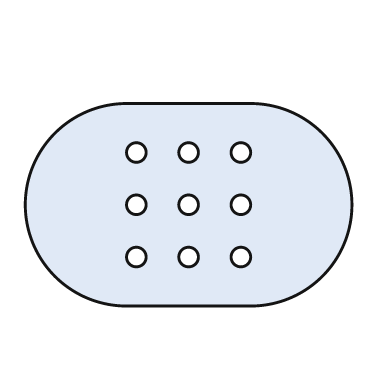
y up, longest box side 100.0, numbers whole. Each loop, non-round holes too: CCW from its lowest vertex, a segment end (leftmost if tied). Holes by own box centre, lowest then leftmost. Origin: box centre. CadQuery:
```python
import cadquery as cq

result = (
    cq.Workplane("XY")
    .moveTo(-19.0, -31.0)
    .lineTo(19.0, -31.0)
    .threePointArc((50.0, 0.0), (19.0, 31.0))
    .lineTo(-19.0, 31.0)
    .threePointArc((-50.0, 0.0), (-19.0, -31.0))
    .close()
    .moveTo(-16.0, -16.0)
    .circle(3.0)
    .moveTo(0.0, -16.0)
    .circle(3.0)
    .moveTo(16.0, -16.0)
    .circle(3.0)
    .moveTo(-16.0, 0.0)
    .circle(3.0)
    .moveTo(0.0, 0.0)
    .circle(3.0)
    .moveTo(16.0, 0.0)
    .circle(3.0)
    .moveTo(-16.0, 16.0)
    .circle(3.0)
    .moveTo(0.0, 16.0)
    .circle(3.0)
    .moveTo(16.0, 16.0)
    .circle(3.0)
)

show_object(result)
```